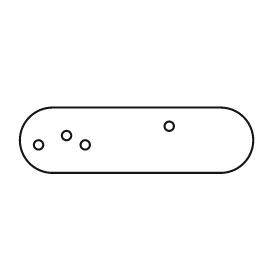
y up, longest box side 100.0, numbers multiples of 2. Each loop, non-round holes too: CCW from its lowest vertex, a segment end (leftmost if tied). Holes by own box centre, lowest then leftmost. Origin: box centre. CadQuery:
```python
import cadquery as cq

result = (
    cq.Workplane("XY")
    .moveTo(-36.0, -14.0)
    .lineTo(36.0, -14.0)
    .threePointArc((50.0, 0.0), (36.0, 14.0))
    .lineTo(-36.0, 14.0)
    .threePointArc((-50.0, 0.0), (-36.0, -14.0))
    .close()
    .moveTo(-42.0, -2.0)
    .circle(2.0)
    .moveTo(-22.0, -2.0)
    .circle(2.0)
    .moveTo(-30.0, 2.0)
    .circle(2.0)
    .moveTo(14.0, 6.0)
    .circle(2.0)
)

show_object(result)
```